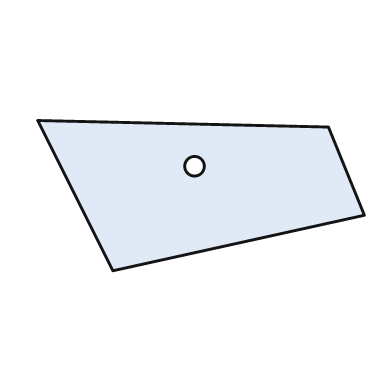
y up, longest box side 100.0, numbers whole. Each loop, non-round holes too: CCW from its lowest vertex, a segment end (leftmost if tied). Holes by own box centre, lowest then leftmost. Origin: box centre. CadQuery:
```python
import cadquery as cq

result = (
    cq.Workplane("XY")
    .moveTo(-27.0, -23.0)
    .lineTo(50.0, -6.0)
    .lineTo(39.0, 21.0)
    .lineTo(-50.0, 23.0)
    .close()
    .moveTo(-2.0, 9.0)
    .circle(3.0)
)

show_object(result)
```